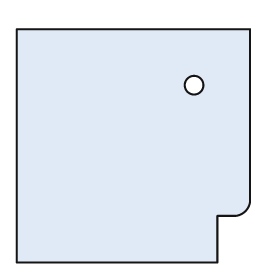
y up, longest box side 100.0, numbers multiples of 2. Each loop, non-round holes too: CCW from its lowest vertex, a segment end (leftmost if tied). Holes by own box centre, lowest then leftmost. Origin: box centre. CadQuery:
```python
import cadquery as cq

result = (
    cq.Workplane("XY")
    .moveTo(-50.0, -50.0)
    .lineTo(36.0, -50.0)
    .lineTo(36.0, -30.0)
    .lineTo(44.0, -30.0)
    .threePointArc((48.0, -28.0), (50.0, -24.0))
    .lineTo(50.0, 50.0)
    .lineTo(-50.0, 50.0)
    .close()
    .moveTo(26.0, 26.0)
    .circle(4.0)
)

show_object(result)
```